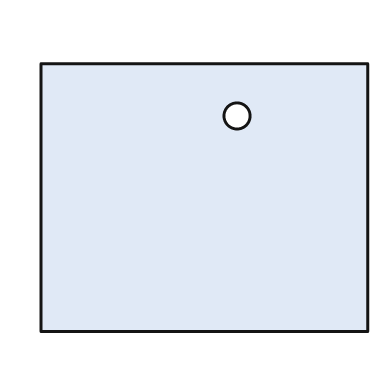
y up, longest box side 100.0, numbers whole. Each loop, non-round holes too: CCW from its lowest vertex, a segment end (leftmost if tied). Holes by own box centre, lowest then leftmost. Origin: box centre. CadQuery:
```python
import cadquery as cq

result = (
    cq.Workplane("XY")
    .moveTo(-50.0, -41.0)
    .lineTo(50.0, -41.0)
    .lineTo(50.0, 41.0)
    .lineTo(-50.0, 41.0)
    .close()
    .moveTo(10.0, 25.0)
    .circle(4.0)
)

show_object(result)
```